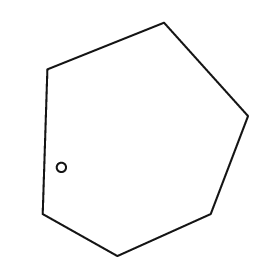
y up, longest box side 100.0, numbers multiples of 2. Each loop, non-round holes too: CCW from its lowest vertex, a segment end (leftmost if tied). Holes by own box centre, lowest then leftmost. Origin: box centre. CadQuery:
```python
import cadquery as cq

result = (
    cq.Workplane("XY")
    .moveTo(-12.0, -50.0)
    .lineTo(28.0, -32.0)
    .lineTo(44.0, 10.0)
    .lineTo(8.0, 50.0)
    .lineTo(-42.0, 30.0)
    .lineTo(-44.0, -32.0)
    .close()
    .moveTo(-36.0, -12.0)
    .circle(2.0)
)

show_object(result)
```